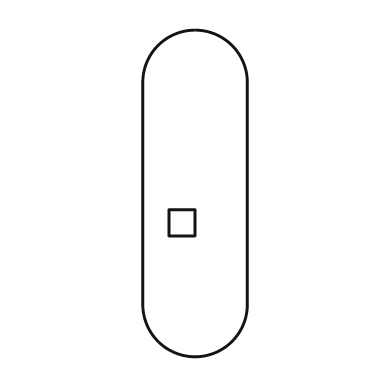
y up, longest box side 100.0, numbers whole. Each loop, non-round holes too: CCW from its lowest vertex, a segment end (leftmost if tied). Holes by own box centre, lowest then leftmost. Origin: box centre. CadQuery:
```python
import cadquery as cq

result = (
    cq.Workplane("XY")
    .moveTo(-16.0, -34.0)
    .threePointArc((0.0, -50.0), (16.0, -34.0))
    .lineTo(16.0, 34.0)
    .threePointArc((0.0, 50.0), (-16.0, 34.0))
    .close()
    .moveTo(-8.0, -13.0)
    .lineTo(0.0, -13.0)
    .lineTo(0.0, -5.0)
    .lineTo(-8.0, -5.0)
    .close()
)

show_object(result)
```